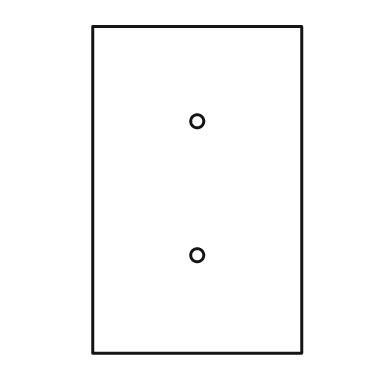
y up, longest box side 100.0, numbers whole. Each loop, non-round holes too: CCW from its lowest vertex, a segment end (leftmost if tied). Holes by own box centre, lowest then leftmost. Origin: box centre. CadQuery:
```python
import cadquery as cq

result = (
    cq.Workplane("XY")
    .moveTo(-32.0, -50.0)
    .lineTo(32.0, -50.0)
    .lineTo(32.0, 50.0)
    .lineTo(-32.0, 50.0)
    .close()
    .moveTo(0.0, -20.0)
    .circle(2.0)
    .moveTo(0.0, 21.0)
    .circle(2.0)
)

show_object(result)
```